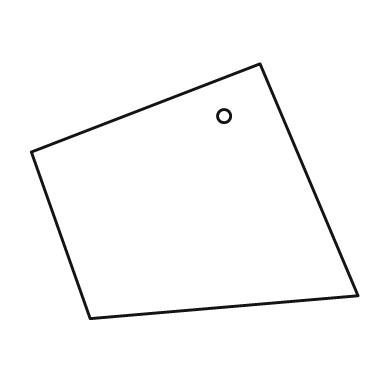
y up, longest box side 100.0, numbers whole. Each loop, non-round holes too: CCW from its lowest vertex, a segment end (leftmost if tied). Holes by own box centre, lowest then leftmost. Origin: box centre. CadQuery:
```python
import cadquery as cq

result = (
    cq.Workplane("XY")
    .moveTo(-32.0, -39.0)
    .lineTo(50.0, -32.0)
    .lineTo(20.0, 39.0)
    .lineTo(-50.0, 12.0)
    .close()
    .moveTo(9.0, 23.0)
    .circle(2.0)
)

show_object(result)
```